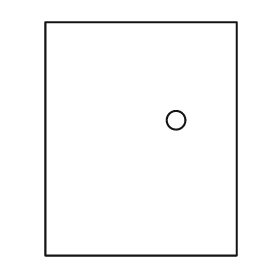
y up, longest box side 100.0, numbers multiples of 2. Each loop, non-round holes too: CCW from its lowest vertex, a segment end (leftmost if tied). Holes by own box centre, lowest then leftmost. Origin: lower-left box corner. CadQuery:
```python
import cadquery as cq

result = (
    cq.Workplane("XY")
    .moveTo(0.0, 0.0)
    .lineTo(82.0, 0.0)
    .lineTo(82.0, 100.0)
    .lineTo(0.0, 100.0)
    .close()
    .moveTo(56.0, 58.0)
    .circle(4.0)
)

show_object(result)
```